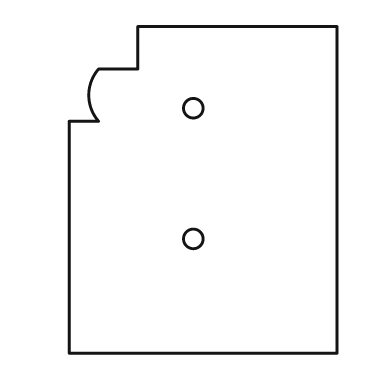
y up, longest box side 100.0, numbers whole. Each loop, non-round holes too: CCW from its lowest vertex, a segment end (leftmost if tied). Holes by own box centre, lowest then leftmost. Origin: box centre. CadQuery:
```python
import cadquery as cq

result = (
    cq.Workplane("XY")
    .moveTo(-41.0, -50.0)
    .lineTo(41.0, -50.0)
    .lineTo(41.0, 50.0)
    .lineTo(-20.0, 50.0)
    .lineTo(-20.0, 37.0)
    .lineTo(-32.0, 37.0)
    .threePointArc((-35.0, 29.0), (-32.0, 21.0))
    .lineTo(-41.0, 21.0)
    .close()
    .moveTo(-3.0, -15.0)
    .circle(3.0)
    .moveTo(-3.0, 25.0)
    .circle(3.0)
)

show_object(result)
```